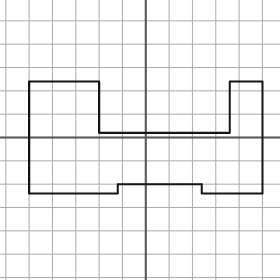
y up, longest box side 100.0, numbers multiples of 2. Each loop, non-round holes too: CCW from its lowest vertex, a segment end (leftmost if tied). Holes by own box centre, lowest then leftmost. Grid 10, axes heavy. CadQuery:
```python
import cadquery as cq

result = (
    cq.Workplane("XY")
    .moveTo(-50.0, -24.0)
    .lineTo(-12.0, -24.0)
    .lineTo(-12.0, -20.0)
    .lineTo(24.0, -20.0)
    .lineTo(24.0, -24.0)
    .lineTo(50.0, -24.0)
    .lineTo(50.0, 24.0)
    .lineTo(36.0, 24.0)
    .lineTo(36.0, 2.0)
    .lineTo(-20.0, 2.0)
    .lineTo(-20.0, 24.0)
    .lineTo(-50.0, 24.0)
    .close()
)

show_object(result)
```